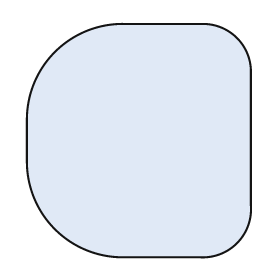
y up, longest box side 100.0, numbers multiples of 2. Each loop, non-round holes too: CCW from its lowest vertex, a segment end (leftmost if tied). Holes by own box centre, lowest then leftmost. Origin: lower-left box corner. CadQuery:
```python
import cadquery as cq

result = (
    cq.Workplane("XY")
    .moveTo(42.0, 0.0)
    .lineTo(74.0, 0.0)
    .threePointArc((90.0, 6.0), (96.0, 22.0))
    .lineTo(96.0, 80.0)
    .threePointArc((90.0, 94.0), (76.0, 100.0))
    .lineTo(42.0, 100.0)
    .threePointArc((12.0, 88.0), (0.0, 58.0))
    .lineTo(0.0, 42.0)
    .threePointArc((12.0, 12.0), (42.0, 0.0))
    .close()
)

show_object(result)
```